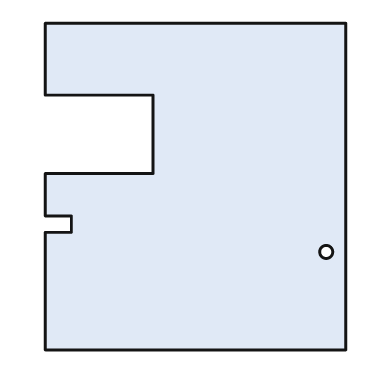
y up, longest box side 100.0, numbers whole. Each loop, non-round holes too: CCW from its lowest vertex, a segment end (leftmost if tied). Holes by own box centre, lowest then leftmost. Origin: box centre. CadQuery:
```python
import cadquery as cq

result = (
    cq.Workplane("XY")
    .moveTo(-46.0, -50.0)
    .lineTo(46.0, -50.0)
    .lineTo(46.0, 50.0)
    .lineTo(-46.0, 50.0)
    .lineTo(-46.0, 28.0)
    .lineTo(-13.0, 28.0)
    .lineTo(-13.0, 4.0)
    .lineTo(-46.0, 4.0)
    .lineTo(-46.0, -9.0)
    .lineTo(-38.0, -9.0)
    .lineTo(-38.0, -14.0)
    .lineTo(-46.0, -14.0)
    .close()
    .moveTo(40.0, -20.0)
    .circle(2.0)
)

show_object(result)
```